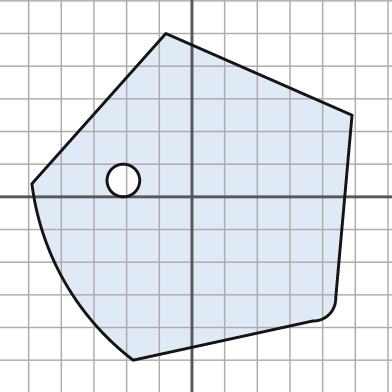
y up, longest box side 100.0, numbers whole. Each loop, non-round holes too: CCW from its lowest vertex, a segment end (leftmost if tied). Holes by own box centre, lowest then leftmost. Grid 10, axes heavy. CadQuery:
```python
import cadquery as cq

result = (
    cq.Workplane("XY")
    .moveTo(-18.0, -50.0)
    .lineTo(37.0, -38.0)
    .threePointArc((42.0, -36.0), (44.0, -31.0))
    .lineTo(49.0, 25.0)
    .lineTo(-8.0, 50.0)
    .lineTo(-49.0, 4.0)
    .threePointArc((-39.0, -26.0), (-18.0, -50.0))
    .close()
    .moveTo(-21.0, 5.0)
    .circle(5.0)
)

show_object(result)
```